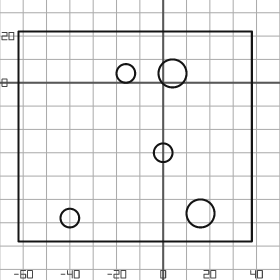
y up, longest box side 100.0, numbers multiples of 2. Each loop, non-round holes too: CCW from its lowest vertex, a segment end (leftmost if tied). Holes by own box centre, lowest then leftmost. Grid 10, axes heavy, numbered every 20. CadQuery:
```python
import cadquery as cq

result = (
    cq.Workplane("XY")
    .moveTo(-62.0, -68.0)
    .lineTo(38.0, -68.0)
    .lineTo(38.0, 22.0)
    .lineTo(-62.0, 22.0)
    .close()
    .moveTo(-40.0, -58.0)
    .circle(4.0)
    .moveTo(16.0, -56.0)
    .circle(6.0)
    .moveTo(0.0, -30.0)
    .circle(4.0)
    .moveTo(-16.0, 4.0)
    .circle(4.0)
    .moveTo(4.0, 4.0)
    .circle(6.0)
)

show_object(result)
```